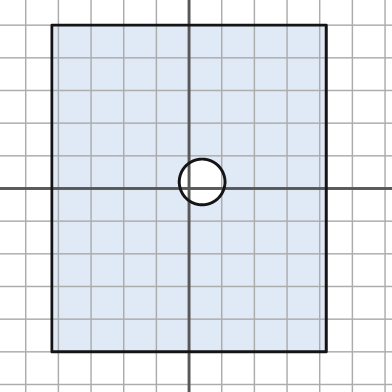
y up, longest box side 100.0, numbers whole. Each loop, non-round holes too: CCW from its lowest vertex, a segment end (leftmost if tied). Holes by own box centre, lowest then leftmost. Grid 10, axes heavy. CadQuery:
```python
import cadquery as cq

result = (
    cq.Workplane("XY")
    .moveTo(-42.0, -50.0)
    .lineTo(42.0, -50.0)
    .lineTo(42.0, 50.0)
    .lineTo(-42.0, 50.0)
    .close()
    .moveTo(4.0, 2.0)
    .circle(7.0)
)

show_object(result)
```